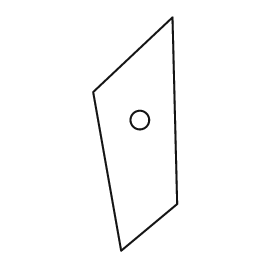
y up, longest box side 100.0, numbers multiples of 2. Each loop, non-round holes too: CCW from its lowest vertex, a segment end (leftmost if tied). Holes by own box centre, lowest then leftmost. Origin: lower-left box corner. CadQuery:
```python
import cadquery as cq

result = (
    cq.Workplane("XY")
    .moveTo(12.0, 0.0)
    .lineTo(36.0, 20.0)
    .lineTo(34.0, 100.0)
    .lineTo(0.0, 68.0)
    .close()
    .moveTo(20.0, 56.0)
    .circle(4.0)
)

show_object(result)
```